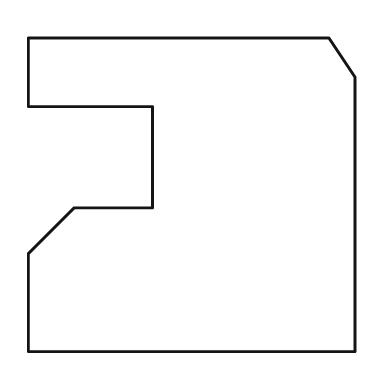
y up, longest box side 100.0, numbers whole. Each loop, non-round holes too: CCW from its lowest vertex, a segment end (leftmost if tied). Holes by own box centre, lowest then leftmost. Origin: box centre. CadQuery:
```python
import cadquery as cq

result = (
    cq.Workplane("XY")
    .moveTo(-50.0, -48.0)
    .lineTo(50.0, -48.0)
    .lineTo(50.0, 36.0)
    .lineTo(42.0, 48.0)
    .lineTo(-50.0, 48.0)
    .lineTo(-50.0, 27.0)
    .lineTo(-12.0, 27.0)
    .lineTo(-12.0, -4.0)
    .lineTo(-36.0, -4.0)
    .lineTo(-50.0, -18.0)
    .close()
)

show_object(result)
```